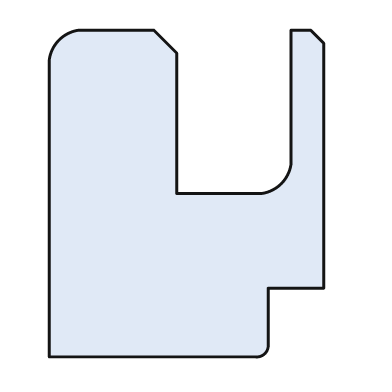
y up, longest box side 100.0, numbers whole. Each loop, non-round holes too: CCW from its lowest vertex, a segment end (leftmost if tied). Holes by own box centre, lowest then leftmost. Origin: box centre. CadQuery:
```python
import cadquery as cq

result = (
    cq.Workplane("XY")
    .moveTo(-42.0, -50.0)
    .lineTo(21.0, -50.0)
    .threePointArc((24.0, -49.0), (25.0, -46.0))
    .lineTo(25.0, -29.0)
    .lineTo(42.0, -29.0)
    .lineTo(42.0, 46.0)
    .lineTo(38.0, 50.0)
    .lineTo(32.0, 50.0)
    .lineTo(32.0, 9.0)
    .threePointArc((29.0, 3.0), (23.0, 0.0))
    .lineTo(-3.0, 0.0)
    .lineTo(-3.0, 43.0)
    .lineTo(-10.0, 50.0)
    .lineTo(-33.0, 50.0)
    .threePointArc((-39.0, 47.0), (-42.0, 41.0))
    .close()
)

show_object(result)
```